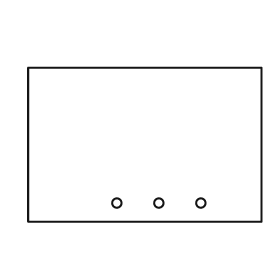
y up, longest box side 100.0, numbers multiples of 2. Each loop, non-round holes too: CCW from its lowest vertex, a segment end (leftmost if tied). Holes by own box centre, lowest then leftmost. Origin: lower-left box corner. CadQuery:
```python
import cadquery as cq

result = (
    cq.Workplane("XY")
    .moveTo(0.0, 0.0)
    .lineTo(100.0, 0.0)
    .lineTo(100.0, 66.0)
    .lineTo(0.0, 66.0)
    .close()
    .moveTo(38.0, 8.0)
    .circle(2.0)
    .moveTo(56.0, 8.0)
    .circle(2.0)
    .moveTo(74.0, 8.0)
    .circle(2.0)
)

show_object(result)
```